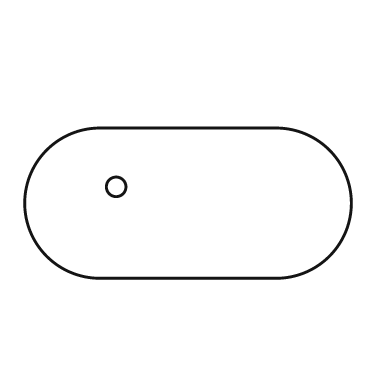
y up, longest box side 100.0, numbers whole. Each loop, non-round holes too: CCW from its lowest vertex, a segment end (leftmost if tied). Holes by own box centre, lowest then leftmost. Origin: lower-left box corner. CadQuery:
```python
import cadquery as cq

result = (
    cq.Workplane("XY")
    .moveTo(23.0, 0.0)
    .lineTo(77.0, 0.0)
    .threePointArc((100.0, 23.0), (77.0, 46.0))
    .lineTo(23.0, 46.0)
    .threePointArc((0.0, 23.0), (23.0, 0.0))
    .close()
    .moveTo(28.0, 28.0)
    .circle(3.0)
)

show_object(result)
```